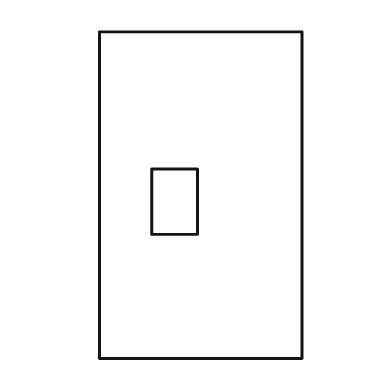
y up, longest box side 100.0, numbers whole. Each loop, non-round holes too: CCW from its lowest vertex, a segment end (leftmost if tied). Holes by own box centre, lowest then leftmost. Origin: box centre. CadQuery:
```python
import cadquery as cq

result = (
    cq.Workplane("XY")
    .moveTo(-31.0, -50.0)
    .lineTo(31.0, -50.0)
    .lineTo(31.0, 50.0)
    .lineTo(-31.0, 50.0)
    .close()
    .moveTo(-15.0, -12.0)
    .lineTo(-1.0, -12.0)
    .lineTo(-1.0, 8.0)
    .lineTo(-15.0, 8.0)
    .close()
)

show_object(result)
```